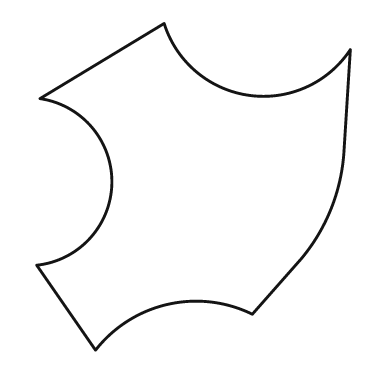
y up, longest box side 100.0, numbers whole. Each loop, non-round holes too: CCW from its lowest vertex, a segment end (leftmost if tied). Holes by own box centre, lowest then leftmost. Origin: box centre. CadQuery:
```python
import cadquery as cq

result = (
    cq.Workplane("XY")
    .moveTo(-30.0, -50.0)
    .threePointArc((-8.0, -36.0), (18.0, -39.0))
    .lineTo(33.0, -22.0)
    .threePointArc((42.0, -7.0), (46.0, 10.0))
    .lineTo(48.0, 42.0)
    .threePointArc((17.0, 28.0), (-9.0, 50.0))
    .lineTo(-47.0, 27.0)
    .threePointArc((-25.0, 1.0), (-48.0, -24.0))
    .close()
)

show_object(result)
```